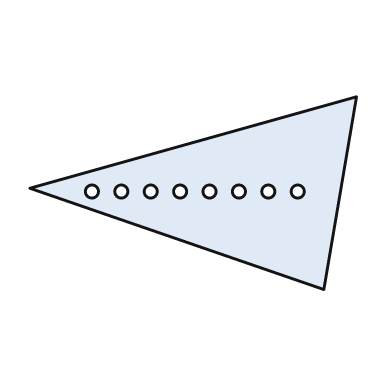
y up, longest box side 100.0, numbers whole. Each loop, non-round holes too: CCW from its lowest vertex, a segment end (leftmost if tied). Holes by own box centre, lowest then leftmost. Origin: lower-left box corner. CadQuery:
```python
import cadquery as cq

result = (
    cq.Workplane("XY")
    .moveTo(90.0, 0.0)
    .lineTo(100.0, 59.0)
    .lineTo(0.0, 31.0)
    .close()
    .moveTo(19.0, 30.0)
    .circle(2.0)
    .moveTo(28.0, 30.0)
    .circle(2.0)
    .moveTo(37.0, 30.0)
    .circle(2.0)
    .moveTo(46.0, 30.0)
    .circle(2.0)
    .moveTo(55.0, 30.0)
    .circle(2.0)
    .moveTo(64.0, 30.0)
    .circle(2.0)
    .moveTo(73.0, 30.0)
    .circle(2.0)
    .moveTo(82.0, 30.0)
    .circle(2.0)
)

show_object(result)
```